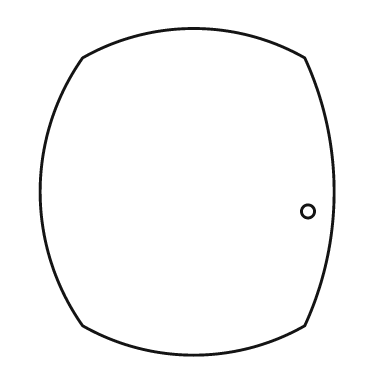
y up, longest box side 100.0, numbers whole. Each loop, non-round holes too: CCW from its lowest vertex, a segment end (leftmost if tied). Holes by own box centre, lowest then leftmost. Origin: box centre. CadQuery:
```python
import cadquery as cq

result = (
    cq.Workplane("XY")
    .moveTo(-32.0, -41.0)
    .threePointArc((2.0, -50.0), (36.0, -41.0))
    .threePointArc((45.0, 0.0), (36.0, 41.0))
    .threePointArc((2.0, 50.0), (-32.0, 41.0))
    .threePointArc((-45.0, 0.0), (-32.0, -41.0))
    .close()
    .moveTo(37.0, -6.0)
    .circle(2.0)
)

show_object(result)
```